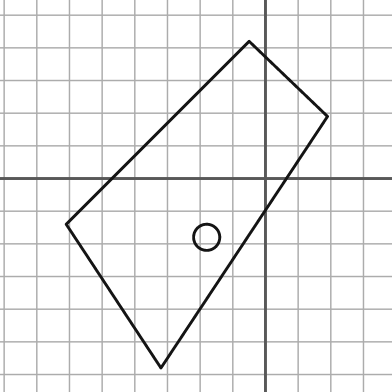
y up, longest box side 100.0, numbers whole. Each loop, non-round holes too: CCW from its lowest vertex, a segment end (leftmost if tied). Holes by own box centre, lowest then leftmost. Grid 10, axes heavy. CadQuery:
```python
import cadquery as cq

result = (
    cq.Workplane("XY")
    .moveTo(-32.0, -58.0)
    .lineTo(19.0, 19.0)
    .lineTo(-5.0, 42.0)
    .lineTo(-61.0, -14.0)
    .close()
    .moveTo(-18.0, -18.0)
    .circle(4.0)
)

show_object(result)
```